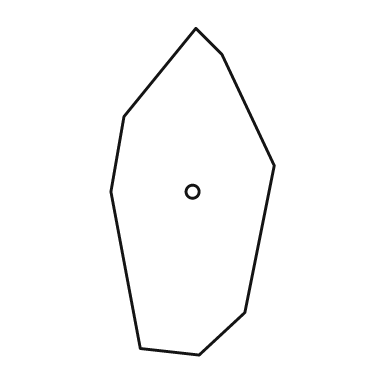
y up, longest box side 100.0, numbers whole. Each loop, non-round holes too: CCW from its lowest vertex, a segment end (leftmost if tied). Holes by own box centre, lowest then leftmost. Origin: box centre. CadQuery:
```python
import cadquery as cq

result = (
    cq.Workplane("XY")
    .moveTo(2.0, -50.0)
    .lineTo(16.0, -37.0)
    .lineTo(25.0, 8.0)
    .lineTo(9.0, 42.0)
    .lineTo(1.0, 50.0)
    .lineTo(-21.0, 23.0)
    .lineTo(-25.0, 0.0)
    .lineTo(-16.0, -48.0)
    .close()
    .moveTo(0.0, 0.0)
    .circle(2.0)
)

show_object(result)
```